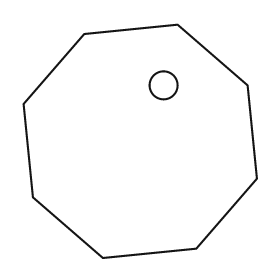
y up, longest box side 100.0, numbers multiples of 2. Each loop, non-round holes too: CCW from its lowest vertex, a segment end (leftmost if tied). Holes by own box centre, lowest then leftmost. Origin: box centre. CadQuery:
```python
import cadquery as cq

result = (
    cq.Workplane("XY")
    .moveTo(-16.0, -50.0)
    .lineTo(24.0, -46.0)
    .lineTo(50.0, -16.0)
    .lineTo(46.0, 24.0)
    .lineTo(16.0, 50.0)
    .lineTo(-24.0, 46.0)
    .lineTo(-50.0, 16.0)
    .lineTo(-46.0, -24.0)
    .close()
    .moveTo(10.0, 24.0)
    .circle(6.0)
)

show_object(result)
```